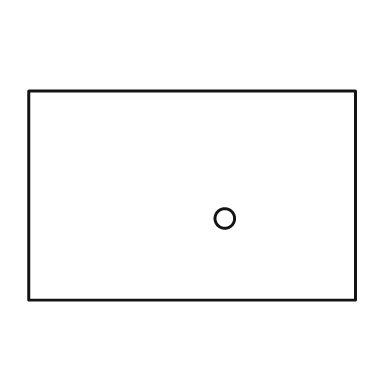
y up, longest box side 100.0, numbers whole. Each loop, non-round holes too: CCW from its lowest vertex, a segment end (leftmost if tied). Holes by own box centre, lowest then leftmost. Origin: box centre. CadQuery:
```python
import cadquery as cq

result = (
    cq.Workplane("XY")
    .moveTo(-50.0, -32.0)
    .lineTo(50.0, -32.0)
    .lineTo(50.0, 32.0)
    .lineTo(-50.0, 32.0)
    .close()
    .moveTo(10.0, -7.0)
    .circle(3.0)
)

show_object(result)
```